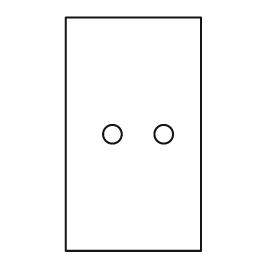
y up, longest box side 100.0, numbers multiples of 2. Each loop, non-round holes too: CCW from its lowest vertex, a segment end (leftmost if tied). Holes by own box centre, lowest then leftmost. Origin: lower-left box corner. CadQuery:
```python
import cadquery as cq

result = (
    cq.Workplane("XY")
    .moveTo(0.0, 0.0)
    .lineTo(58.0, 0.0)
    .lineTo(58.0, 100.0)
    .lineTo(0.0, 100.0)
    .close()
    .moveTo(20.0, 50.0)
    .circle(4.0)
    .moveTo(42.0, 50.0)
    .circle(4.0)
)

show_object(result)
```